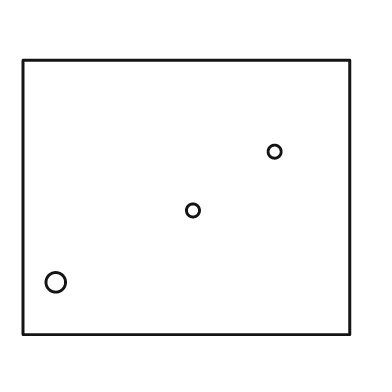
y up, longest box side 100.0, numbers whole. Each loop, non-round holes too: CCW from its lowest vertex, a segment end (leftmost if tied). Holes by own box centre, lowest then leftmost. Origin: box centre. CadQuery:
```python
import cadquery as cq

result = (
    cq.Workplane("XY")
    .moveTo(-50.0, -42.0)
    .lineTo(50.0, -42.0)
    .lineTo(50.0, 42.0)
    .lineTo(-50.0, 42.0)
    .close()
    .moveTo(-40.0, -26.0)
    .circle(3.0)
    .moveTo(2.0, -4.0)
    .circle(2.0)
    .moveTo(27.0, 14.0)
    .circle(2.0)
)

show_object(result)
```